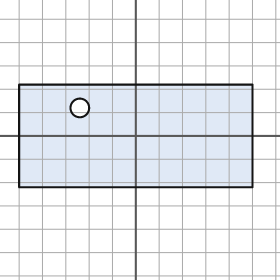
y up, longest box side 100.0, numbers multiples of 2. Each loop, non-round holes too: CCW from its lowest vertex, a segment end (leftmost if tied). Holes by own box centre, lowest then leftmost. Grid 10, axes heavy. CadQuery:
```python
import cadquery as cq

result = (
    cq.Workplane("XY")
    .moveTo(-50.0, -22.0)
    .lineTo(50.0, -22.0)
    .lineTo(50.0, 22.0)
    .lineTo(-50.0, 22.0)
    .close()
    .moveTo(-24.0, 12.0)
    .circle(4.0)
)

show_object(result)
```